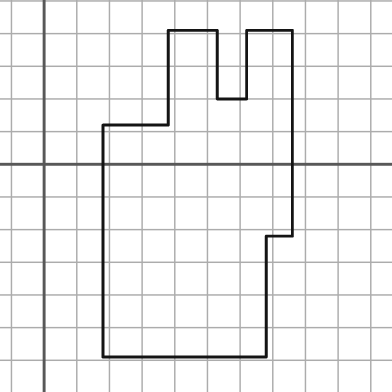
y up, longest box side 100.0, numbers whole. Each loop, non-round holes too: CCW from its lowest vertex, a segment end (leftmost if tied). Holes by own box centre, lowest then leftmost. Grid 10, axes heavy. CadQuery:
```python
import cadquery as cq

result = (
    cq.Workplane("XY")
    .moveTo(18.0, -59.0)
    .lineTo(68.0, -59.0)
    .lineTo(68.0, -22.0)
    .lineTo(76.0, -22.0)
    .lineTo(76.0, 41.0)
    .lineTo(62.0, 41.0)
    .lineTo(62.0, 20.0)
    .lineTo(53.0, 20.0)
    .lineTo(53.0, 41.0)
    .lineTo(38.0, 41.0)
    .lineTo(38.0, 12.0)
    .lineTo(18.0, 12.0)
    .close()
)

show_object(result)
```